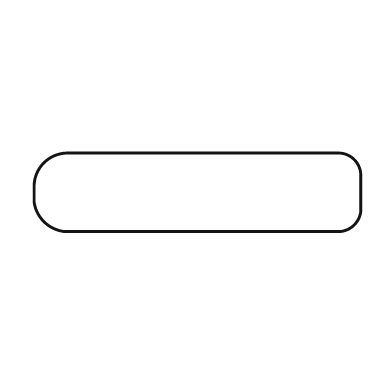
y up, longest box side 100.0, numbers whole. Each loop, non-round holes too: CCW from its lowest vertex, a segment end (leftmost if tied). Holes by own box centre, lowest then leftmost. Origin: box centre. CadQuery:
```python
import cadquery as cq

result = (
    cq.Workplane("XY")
    .moveTo(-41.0, -12.0)
    .lineTo(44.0, -12.0)
    .threePointArc((48.0, -10.0), (50.0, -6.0))
    .lineTo(50.0, 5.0)
    .threePointArc((48.0, 10.0), (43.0, 12.0))
    .lineTo(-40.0, 12.0)
    .threePointArc((-47.0, 9.0), (-50.0, 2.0))
    .lineTo(-50.0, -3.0)
    .threePointArc((-47.0, -9.0), (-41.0, -12.0))
    .close()
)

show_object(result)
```